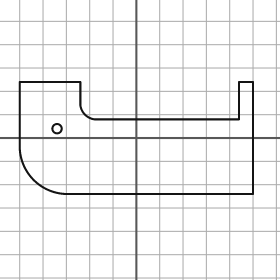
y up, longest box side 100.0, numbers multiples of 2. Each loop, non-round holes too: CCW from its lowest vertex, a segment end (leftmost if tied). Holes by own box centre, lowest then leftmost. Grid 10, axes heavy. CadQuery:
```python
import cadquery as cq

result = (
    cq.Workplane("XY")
    .moveTo(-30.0, -24.0)
    .lineTo(50.0, -24.0)
    .lineTo(50.0, 24.0)
    .lineTo(44.0, 24.0)
    .lineTo(44.0, 8.0)
    .lineTo(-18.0, 8.0)
    .threePointArc((-22.0, 10.0), (-24.0, 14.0))
    .lineTo(-24.0, 24.0)
    .lineTo(-50.0, 24.0)
    .lineTo(-50.0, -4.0)
    .threePointArc((-44.0, -18.0), (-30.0, -24.0))
    .close()
    .moveTo(-34.0, 4.0)
    .circle(2.0)
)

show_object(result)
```